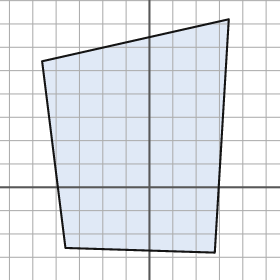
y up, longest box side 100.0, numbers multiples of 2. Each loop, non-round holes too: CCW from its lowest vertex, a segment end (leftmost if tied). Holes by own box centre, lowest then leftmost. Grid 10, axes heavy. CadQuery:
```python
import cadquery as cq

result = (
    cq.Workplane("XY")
    .moveTo(28.0, -28.0)
    .lineTo(34.0, 72.0)
    .lineTo(-46.0, 54.0)
    .lineTo(-36.0, -26.0)
    .close()
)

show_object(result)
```